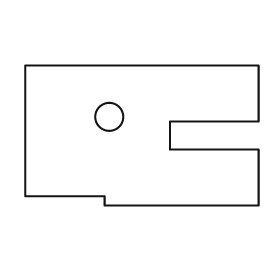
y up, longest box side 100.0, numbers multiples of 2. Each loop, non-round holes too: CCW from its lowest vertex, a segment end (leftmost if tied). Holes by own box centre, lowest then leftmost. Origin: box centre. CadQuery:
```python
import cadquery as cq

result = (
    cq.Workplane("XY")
    .moveTo(-16.0, -30.0)
    .lineTo(50.0, -30.0)
    .lineTo(50.0, -6.0)
    .lineTo(12.0, -6.0)
    .lineTo(12.0, 6.0)
    .lineTo(50.0, 6.0)
    .lineTo(50.0, 30.0)
    .lineTo(-50.0, 30.0)
    .lineTo(-50.0, -26.0)
    .lineTo(-16.0, -26.0)
    .close()
    .moveTo(-14.0, 8.0)
    .circle(6.0)
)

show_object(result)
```